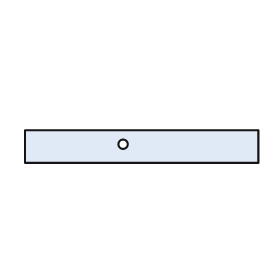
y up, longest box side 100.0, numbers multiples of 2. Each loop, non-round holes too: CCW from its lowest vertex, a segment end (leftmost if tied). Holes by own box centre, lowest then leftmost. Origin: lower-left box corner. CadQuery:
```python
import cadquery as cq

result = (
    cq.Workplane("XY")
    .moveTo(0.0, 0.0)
    .lineTo(100.0, 0.0)
    .lineTo(100.0, 14.0)
    .lineTo(0.0, 14.0)
    .close()
    .moveTo(42.0, 8.0)
    .circle(2.0)
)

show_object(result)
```